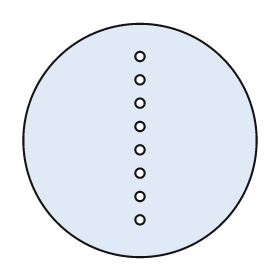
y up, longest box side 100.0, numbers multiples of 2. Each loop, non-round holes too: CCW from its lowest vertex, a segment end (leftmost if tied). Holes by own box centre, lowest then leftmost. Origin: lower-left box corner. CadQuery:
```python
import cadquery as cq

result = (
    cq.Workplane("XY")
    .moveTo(50.0, 50.0)
    .circle(50.0)
    .moveTo(50.0, 16.0)
    .circle(2.0)
    .moveTo(50.0, 26.0)
    .circle(2.0)
    .moveTo(50.0, 36.0)
    .circle(2.0)
    .moveTo(50.0, 46.0)
    .circle(2.0)
    .moveTo(50.0, 56.0)
    .circle(2.0)
    .moveTo(50.0, 66.0)
    .circle(2.0)
    .moveTo(50.0, 76.0)
    .circle(2.0)
    .moveTo(50.0, 86.0)
    .circle(2.0)
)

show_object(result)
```